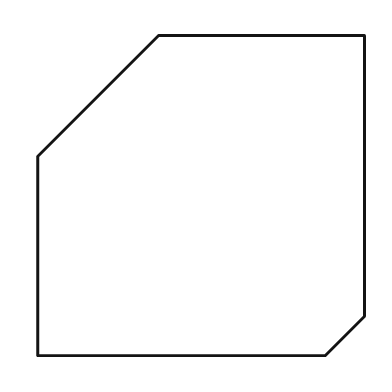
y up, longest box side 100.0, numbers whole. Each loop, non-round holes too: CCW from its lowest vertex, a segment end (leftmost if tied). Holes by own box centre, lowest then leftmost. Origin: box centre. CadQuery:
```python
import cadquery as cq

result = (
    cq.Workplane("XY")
    .moveTo(-50.0, -49.0)
    .lineTo(38.0, -49.0)
    .lineTo(50.0, -37.0)
    .lineTo(50.0, 49.0)
    .lineTo(-13.0, 49.0)
    .lineTo(-50.0, 12.0)
    .close()
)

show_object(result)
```